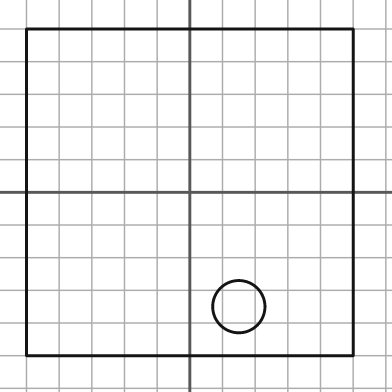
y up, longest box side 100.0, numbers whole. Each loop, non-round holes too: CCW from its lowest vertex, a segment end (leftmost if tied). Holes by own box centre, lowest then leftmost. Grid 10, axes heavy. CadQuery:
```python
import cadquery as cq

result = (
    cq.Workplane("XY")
    .moveTo(-50.0, -50.0)
    .lineTo(50.0, -50.0)
    .lineTo(50.0, 50.0)
    .lineTo(-50.0, 50.0)
    .close()
    .moveTo(15.0, -35.0)
    .circle(8.0)
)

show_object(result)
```